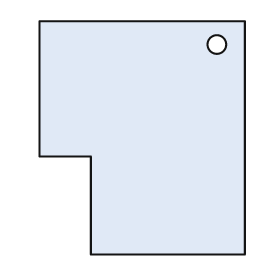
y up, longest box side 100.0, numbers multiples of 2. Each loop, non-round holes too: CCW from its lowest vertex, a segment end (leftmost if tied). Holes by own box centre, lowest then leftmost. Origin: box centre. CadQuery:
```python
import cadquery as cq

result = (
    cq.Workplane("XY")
    .moveTo(-22.0, -50.0)
    .lineTo(44.0, -50.0)
    .lineTo(44.0, 50.0)
    .lineTo(-44.0, 50.0)
    .lineTo(-44.0, -8.0)
    .lineTo(-22.0, -8.0)
    .close()
    .moveTo(32.0, 40.0)
    .circle(4.0)
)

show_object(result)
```